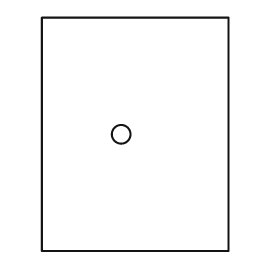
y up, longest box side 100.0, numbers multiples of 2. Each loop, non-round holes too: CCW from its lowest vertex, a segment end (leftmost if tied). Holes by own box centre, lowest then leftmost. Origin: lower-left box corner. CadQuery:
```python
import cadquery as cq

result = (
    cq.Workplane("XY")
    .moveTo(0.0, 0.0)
    .lineTo(80.0, 0.0)
    .lineTo(80.0, 100.0)
    .lineTo(0.0, 100.0)
    .close()
    .moveTo(34.0, 50.0)
    .circle(4.0)
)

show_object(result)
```